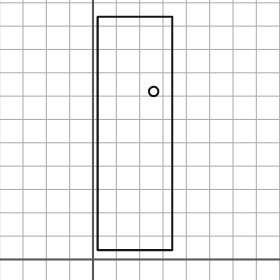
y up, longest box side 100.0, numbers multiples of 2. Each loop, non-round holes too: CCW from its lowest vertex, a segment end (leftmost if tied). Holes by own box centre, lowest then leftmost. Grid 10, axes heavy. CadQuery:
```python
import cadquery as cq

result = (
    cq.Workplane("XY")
    .moveTo(2.0, 4.0)
    .lineTo(34.0, 4.0)
    .lineTo(34.0, 104.0)
    .lineTo(2.0, 104.0)
    .close()
    .moveTo(26.0, 72.0)
    .circle(2.0)
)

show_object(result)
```